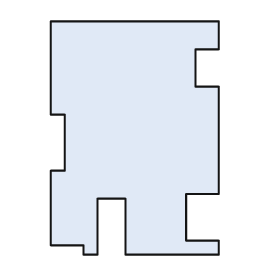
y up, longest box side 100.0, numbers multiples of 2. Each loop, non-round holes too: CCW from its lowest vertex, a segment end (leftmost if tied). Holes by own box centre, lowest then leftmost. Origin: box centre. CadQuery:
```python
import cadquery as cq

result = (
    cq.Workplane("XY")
    .moveTo(-22.0, -50.0)
    .lineTo(-16.0, -50.0)
    .lineTo(-16.0, -26.0)
    .lineTo(-4.0, -26.0)
    .lineTo(-4.0, -50.0)
    .lineTo(36.0, -50.0)
    .lineTo(36.0, -44.0)
    .lineTo(22.0, -44.0)
    .lineTo(22.0, -24.0)
    .lineTo(36.0, -24.0)
    .lineTo(36.0, 22.0)
    .lineTo(26.0, 22.0)
    .lineTo(26.0, 38.0)
    .lineTo(36.0, 38.0)
    .lineTo(36.0, 50.0)
    .lineTo(-36.0, 50.0)
    .lineTo(-36.0, 10.0)
    .lineTo(-30.0, 10.0)
    .lineTo(-30.0, -14.0)
    .lineTo(-36.0, -14.0)
    .lineTo(-36.0, -46.0)
    .lineTo(-22.0, -46.0)
    .close()
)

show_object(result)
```